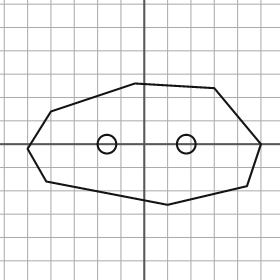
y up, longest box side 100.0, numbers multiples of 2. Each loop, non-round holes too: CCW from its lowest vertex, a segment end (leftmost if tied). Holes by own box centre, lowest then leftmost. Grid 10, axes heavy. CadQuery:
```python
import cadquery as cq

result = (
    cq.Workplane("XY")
    .moveTo(10.0, -26.0)
    .lineTo(44.0, -18.0)
    .lineTo(50.0, 0.0)
    .lineTo(30.0, 24.0)
    .lineTo(-4.0, 26.0)
    .lineTo(-40.0, 14.0)
    .lineTo(-50.0, -2.0)
    .lineTo(-42.0, -16.0)
    .close()
    .moveTo(-16.0, 0.0)
    .circle(4.0)
    .moveTo(18.0, 0.0)
    .circle(4.0)
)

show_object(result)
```